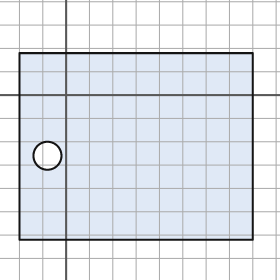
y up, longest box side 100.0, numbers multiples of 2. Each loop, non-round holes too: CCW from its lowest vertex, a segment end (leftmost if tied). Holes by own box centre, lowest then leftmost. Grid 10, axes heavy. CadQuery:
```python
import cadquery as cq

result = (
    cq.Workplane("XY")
    .moveTo(-20.0, -62.0)
    .lineTo(80.0, -62.0)
    .lineTo(80.0, 18.0)
    .lineTo(-20.0, 18.0)
    .close()
    .moveTo(-8.0, -26.0)
    .circle(6.0)
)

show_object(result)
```